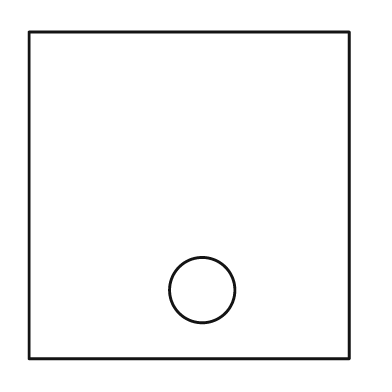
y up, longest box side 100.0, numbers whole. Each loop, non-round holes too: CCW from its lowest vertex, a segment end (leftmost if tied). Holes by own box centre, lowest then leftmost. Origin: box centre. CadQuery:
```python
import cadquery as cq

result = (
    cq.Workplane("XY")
    .moveTo(-49.0, -50.0)
    .lineTo(49.0, -50.0)
    .lineTo(49.0, 50.0)
    .lineTo(-49.0, 50.0)
    .close()
    .moveTo(4.0, -29.0)
    .circle(10.0)
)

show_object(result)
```